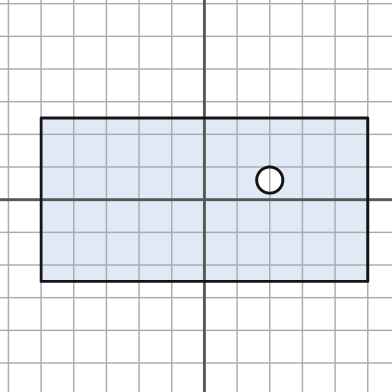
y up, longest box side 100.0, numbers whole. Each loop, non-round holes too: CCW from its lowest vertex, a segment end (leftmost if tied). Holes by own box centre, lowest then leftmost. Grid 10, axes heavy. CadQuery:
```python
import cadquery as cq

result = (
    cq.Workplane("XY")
    .moveTo(-50.0, -25.0)
    .lineTo(50.0, -25.0)
    .lineTo(50.0, 25.0)
    .lineTo(-50.0, 25.0)
    .close()
    .moveTo(20.0, 6.0)
    .circle(4.0)
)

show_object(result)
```